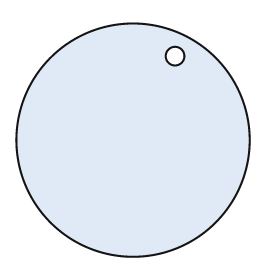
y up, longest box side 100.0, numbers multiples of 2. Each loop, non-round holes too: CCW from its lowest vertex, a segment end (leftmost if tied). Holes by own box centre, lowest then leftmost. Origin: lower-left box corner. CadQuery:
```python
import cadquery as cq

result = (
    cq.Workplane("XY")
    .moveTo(50.0, 50.0)
    .circle(50.0)
    .moveTo(68.0, 86.0)
    .circle(4.0)
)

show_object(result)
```